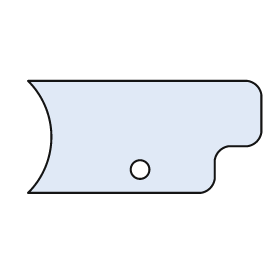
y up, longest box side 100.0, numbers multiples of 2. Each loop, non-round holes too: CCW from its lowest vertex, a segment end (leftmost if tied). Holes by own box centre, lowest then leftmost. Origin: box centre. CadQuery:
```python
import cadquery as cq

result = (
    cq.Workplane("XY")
    .moveTo(-50.0, -24.0)
    .lineTo(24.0, -24.0)
    .threePointArc((28.0, -22.0), (30.0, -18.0))
    .lineTo(30.0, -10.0)
    .threePointArc((32.0, -6.0), (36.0, -4.0))
    .lineTo(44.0, -4.0)
    .threePointArc((48.0, -2.0), (50.0, 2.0))
    .lineTo(50.0, 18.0)
    .threePointArc((48.0, 22.0), (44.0, 24.0))
    .lineTo(-50.0, 24.0)
    .threePointArc((-40.0, 0.0), (-50.0, -24.0))
    .close()
    .moveTo(-2.0, -14.0)
    .circle(4.0)
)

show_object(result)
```